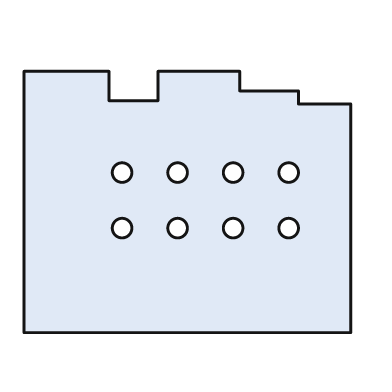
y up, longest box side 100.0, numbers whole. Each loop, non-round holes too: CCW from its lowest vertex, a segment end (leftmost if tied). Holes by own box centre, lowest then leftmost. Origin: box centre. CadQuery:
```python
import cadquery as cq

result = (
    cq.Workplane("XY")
    .moveTo(-50.0, -40.0)
    .lineTo(50.0, -40.0)
    .lineTo(50.0, 30.0)
    .lineTo(34.0, 30.0)
    .lineTo(34.0, 34.0)
    .lineTo(16.0, 34.0)
    .lineTo(16.0, 40.0)
    .lineTo(-9.0, 40.0)
    .lineTo(-9.0, 31.0)
    .lineTo(-24.0, 31.0)
    .lineTo(-24.0, 40.0)
    .lineTo(-50.0, 40.0)
    .close()
    .moveTo(-20.0, -8.0)
    .circle(3.0)
    .moveTo(-3.0, -8.0)
    .circle(3.0)
    .moveTo(14.0, -8.0)
    .circle(3.0)
    .moveTo(31.0, -8.0)
    .circle(3.0)
    .moveTo(-20.0, 9.0)
    .circle(3.0)
    .moveTo(-3.0, 9.0)
    .circle(3.0)
    .moveTo(14.0, 9.0)
    .circle(3.0)
    .moveTo(31.0, 9.0)
    .circle(3.0)
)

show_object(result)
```